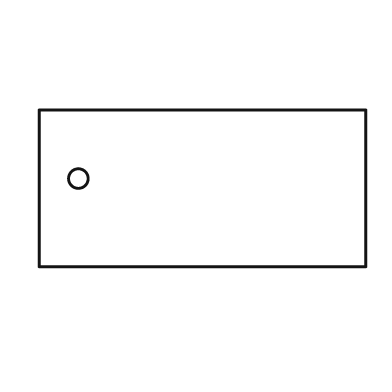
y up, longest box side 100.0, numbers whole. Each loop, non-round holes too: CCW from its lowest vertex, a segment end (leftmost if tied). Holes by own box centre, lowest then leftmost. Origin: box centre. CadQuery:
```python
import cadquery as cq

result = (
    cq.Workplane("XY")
    .moveTo(-50.0, -24.0)
    .lineTo(50.0, -24.0)
    .lineTo(50.0, 24.0)
    .lineTo(-50.0, 24.0)
    .close()
    .moveTo(-38.0, 3.0)
    .circle(3.0)
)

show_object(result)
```